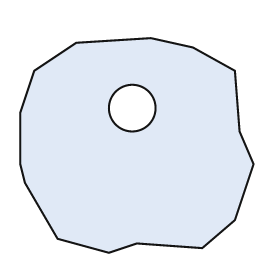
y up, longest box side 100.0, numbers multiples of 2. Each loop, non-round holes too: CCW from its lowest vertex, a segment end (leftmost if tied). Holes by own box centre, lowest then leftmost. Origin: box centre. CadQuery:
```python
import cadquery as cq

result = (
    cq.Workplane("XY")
    .moveTo(-12.0, -46.0)
    .lineTo(0.0, -42.0)
    .lineTo(28.0, -44.0)
    .lineTo(42.0, -32.0)
    .lineTo(50.0, -8.0)
    .lineTo(44.0, 6.0)
    .lineTo(42.0, 32.0)
    .lineTo(24.0, 42.0)
    .lineTo(6.0, 46.0)
    .lineTo(-26.0, 44.0)
    .lineTo(-44.0, 32.0)
    .lineTo(-50.0, 14.0)
    .lineTo(-50.0, -8.0)
    .lineTo(-48.0, -16.0)
    .lineTo(-34.0, -40.0)
    .close()
    .moveTo(-2.0, 16.0)
    .circle(10.0)
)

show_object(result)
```